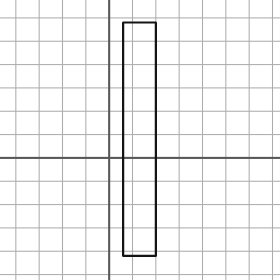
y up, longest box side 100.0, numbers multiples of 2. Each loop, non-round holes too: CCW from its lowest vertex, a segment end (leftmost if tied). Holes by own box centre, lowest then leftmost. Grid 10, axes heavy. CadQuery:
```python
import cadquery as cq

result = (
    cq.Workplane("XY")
    .moveTo(6.0, -42.0)
    .lineTo(20.0, -42.0)
    .lineTo(20.0, 58.0)
    .lineTo(6.0, 58.0)
    .close()
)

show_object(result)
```